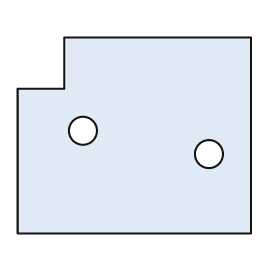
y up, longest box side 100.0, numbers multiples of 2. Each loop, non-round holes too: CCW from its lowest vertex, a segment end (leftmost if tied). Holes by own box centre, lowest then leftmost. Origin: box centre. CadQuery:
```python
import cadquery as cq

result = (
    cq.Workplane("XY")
    .moveTo(-50.0, -42.0)
    .lineTo(50.0, -42.0)
    .lineTo(50.0, 42.0)
    .lineTo(-30.0, 42.0)
    .lineTo(-30.0, 20.0)
    .lineTo(-50.0, 20.0)
    .close()
    .moveTo(32.0, -8.0)
    .circle(6.0)
    .moveTo(-22.0, 2.0)
    .circle(6.0)
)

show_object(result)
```